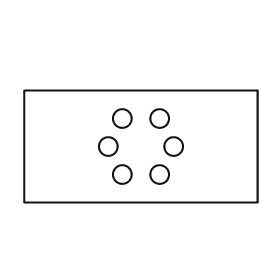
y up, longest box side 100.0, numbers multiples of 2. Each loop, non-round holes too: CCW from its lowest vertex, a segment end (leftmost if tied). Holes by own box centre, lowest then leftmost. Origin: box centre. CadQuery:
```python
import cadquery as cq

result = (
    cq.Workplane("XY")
    .moveTo(-50.0, -24.0)
    .lineTo(50.0, -24.0)
    .lineTo(50.0, 24.0)
    .lineTo(-50.0, 24.0)
    .close()
    .moveTo(-8.0, -12.0)
    .circle(4.0)
    .moveTo(8.0, -12.0)
    .circle(4.0)
    .moveTo(-14.0, 0.0)
    .circle(4.0)
    .moveTo(14.0, 0.0)
    .circle(4.0)
    .moveTo(-8.0, 12.0)
    .circle(4.0)
    .moveTo(8.0, 12.0)
    .circle(4.0)
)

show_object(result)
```